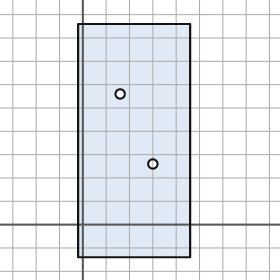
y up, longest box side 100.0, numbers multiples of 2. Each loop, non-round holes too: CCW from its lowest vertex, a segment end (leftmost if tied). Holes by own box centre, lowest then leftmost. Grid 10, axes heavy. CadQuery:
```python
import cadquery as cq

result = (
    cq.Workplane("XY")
    .moveTo(-2.0, -14.0)
    .lineTo(46.0, -14.0)
    .lineTo(46.0, 86.0)
    .lineTo(-2.0, 86.0)
    .close()
    .moveTo(30.0, 26.0)
    .circle(2.0)
    .moveTo(16.0, 56.0)
    .circle(2.0)
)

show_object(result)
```